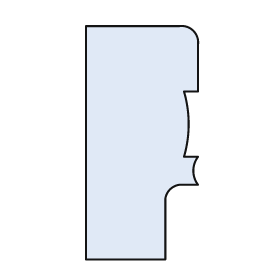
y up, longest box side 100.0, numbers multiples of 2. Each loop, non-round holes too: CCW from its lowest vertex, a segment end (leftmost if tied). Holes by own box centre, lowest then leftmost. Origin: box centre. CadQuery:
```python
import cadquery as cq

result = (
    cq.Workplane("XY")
    .moveTo(-24.0, -50.0)
    .lineTo(10.0, -50.0)
    .lineTo(10.0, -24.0)
    .threePointArc((12.0, -20.0), (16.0, -18.0))
    .lineTo(24.0, -18.0)
    .threePointArc((22.0, -12.0), (24.0, -6.0))
    .lineTo(18.0, -6.0)
    .threePointArc((20.0, 8.0), (18.0, 22.0))
    .lineTo(24.0, 22.0)
    .lineTo(24.0, 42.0)
    .threePointArc((22.0, 48.0), (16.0, 50.0))
    .lineTo(-24.0, 50.0)
    .close()
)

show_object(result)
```